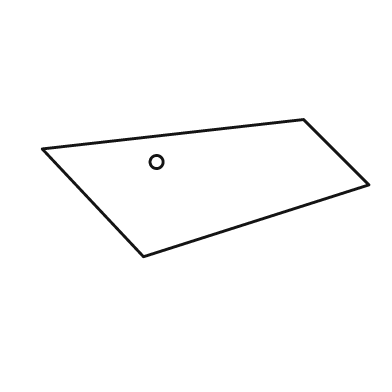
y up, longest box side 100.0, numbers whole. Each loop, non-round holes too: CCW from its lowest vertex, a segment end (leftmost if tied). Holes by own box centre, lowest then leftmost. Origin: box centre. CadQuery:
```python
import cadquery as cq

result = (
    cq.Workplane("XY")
    .moveTo(-19.0, -21.0)
    .lineTo(50.0, 1.0)
    .lineTo(30.0, 21.0)
    .lineTo(-50.0, 12.0)
    .close()
    .moveTo(-15.0, 8.0)
    .circle(2.0)
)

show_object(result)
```